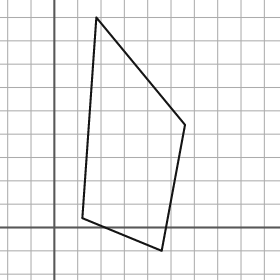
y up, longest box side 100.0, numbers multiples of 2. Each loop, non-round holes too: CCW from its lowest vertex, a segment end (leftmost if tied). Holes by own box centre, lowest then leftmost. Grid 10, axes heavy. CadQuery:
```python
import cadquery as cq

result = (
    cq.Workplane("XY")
    .moveTo(46.0, -10.0)
    .lineTo(56.0, 44.0)
    .lineTo(18.0, 90.0)
    .lineTo(12.0, 4.0)
    .close()
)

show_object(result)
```